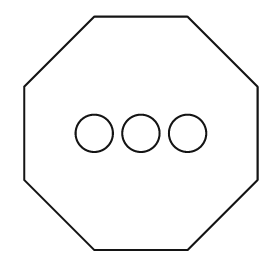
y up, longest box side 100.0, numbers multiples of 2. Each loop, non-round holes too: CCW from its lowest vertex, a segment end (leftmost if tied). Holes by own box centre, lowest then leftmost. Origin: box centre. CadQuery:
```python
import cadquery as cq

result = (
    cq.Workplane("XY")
    .moveTo(-20.0, -50.0)
    .lineTo(20.0, -50.0)
    .lineTo(50.0, -20.0)
    .lineTo(50.0, 20.0)
    .lineTo(20.0, 50.0)
    .lineTo(-20.0, 50.0)
    .lineTo(-50.0, 20.0)
    .lineTo(-50.0, -20.0)
    .close()
    .moveTo(-20.0, 0.0)
    .circle(8.0)
    .moveTo(0.0, 0.0)
    .circle(8.0)
    .moveTo(20.0, 0.0)
    .circle(8.0)
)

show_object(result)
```